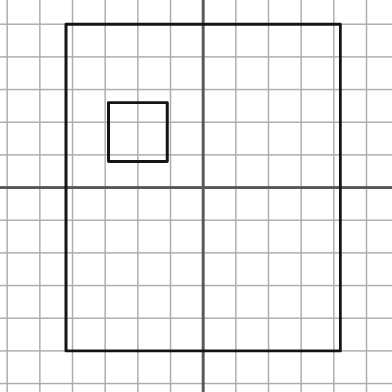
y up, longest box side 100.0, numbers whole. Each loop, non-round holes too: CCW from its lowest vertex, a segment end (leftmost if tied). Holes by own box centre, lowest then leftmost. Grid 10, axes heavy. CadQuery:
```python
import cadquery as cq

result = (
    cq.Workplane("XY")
    .moveTo(-42.0, -50.0)
    .lineTo(42.0, -50.0)
    .lineTo(42.0, 50.0)
    .lineTo(-42.0, 50.0)
    .close()
    .moveTo(-29.0, 8.0)
    .lineTo(-11.0, 8.0)
    .lineTo(-11.0, 26.0)
    .lineTo(-29.0, 26.0)
    .close()
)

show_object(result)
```